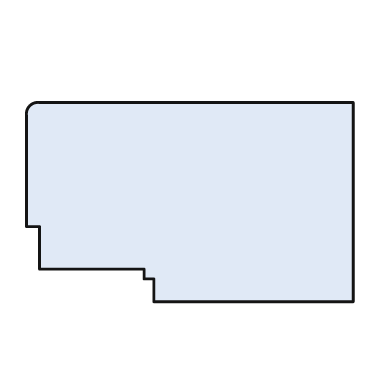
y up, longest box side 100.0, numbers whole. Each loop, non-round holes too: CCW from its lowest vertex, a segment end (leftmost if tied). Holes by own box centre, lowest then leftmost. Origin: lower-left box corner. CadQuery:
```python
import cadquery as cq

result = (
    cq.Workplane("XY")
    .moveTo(39.0, 0.0)
    .lineTo(100.0, 0.0)
    .lineTo(100.0, 61.0)
    .lineTo(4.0, 61.0)
    .threePointArc((1.0, 60.0), (0.0, 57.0))
    .lineTo(0.0, 23.0)
    .lineTo(4.0, 23.0)
    .lineTo(4.0, 10.0)
    .lineTo(36.0, 10.0)
    .lineTo(36.0, 7.0)
    .lineTo(39.0, 7.0)
    .close()
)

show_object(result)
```